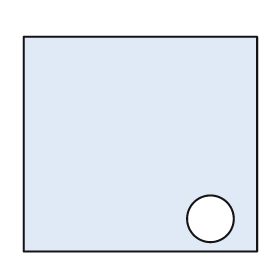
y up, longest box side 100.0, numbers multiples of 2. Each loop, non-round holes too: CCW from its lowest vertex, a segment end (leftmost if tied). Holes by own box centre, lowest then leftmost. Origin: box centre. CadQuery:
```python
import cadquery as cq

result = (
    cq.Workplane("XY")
    .moveTo(-50.0, -46.0)
    .lineTo(50.0, -46.0)
    .lineTo(50.0, 46.0)
    .lineTo(-50.0, 46.0)
    .close()
    .moveTo(30.0, -32.0)
    .circle(10.0)
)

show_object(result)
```